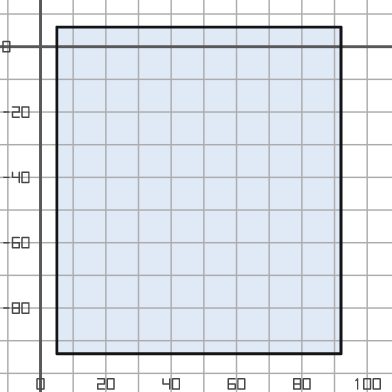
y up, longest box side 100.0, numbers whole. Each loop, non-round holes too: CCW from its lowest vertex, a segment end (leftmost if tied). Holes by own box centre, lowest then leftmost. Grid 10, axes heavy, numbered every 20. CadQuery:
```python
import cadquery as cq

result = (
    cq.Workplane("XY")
    .moveTo(5.0, -94.0)
    .lineTo(92.0, -94.0)
    .lineTo(92.0, 6.0)
    .lineTo(5.0, 6.0)
    .close()
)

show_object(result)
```